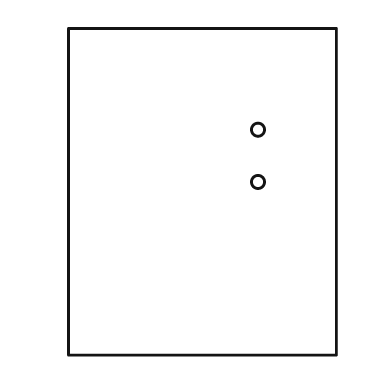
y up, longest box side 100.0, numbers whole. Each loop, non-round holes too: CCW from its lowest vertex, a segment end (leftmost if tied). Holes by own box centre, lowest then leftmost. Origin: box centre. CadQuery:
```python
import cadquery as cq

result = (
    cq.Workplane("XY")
    .moveTo(-41.0, -50.0)
    .lineTo(41.0, -50.0)
    .lineTo(41.0, 50.0)
    .lineTo(-41.0, 50.0)
    .close()
    .moveTo(17.0, 3.0)
    .circle(2.0)
    .moveTo(17.0, 19.0)
    .circle(2.0)
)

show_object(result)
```